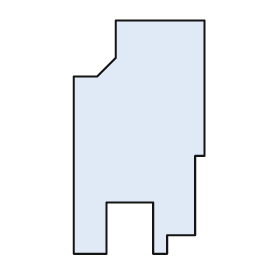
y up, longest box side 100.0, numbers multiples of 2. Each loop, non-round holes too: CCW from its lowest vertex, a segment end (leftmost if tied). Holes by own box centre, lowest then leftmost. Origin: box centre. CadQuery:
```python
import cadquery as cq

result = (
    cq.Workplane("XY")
    .moveTo(-28.0, -50.0)
    .lineTo(-14.0, -50.0)
    .lineTo(-14.0, -28.0)
    .lineTo(6.0, -28.0)
    .lineTo(6.0, -50.0)
    .lineTo(12.0, -50.0)
    .lineTo(12.0, -42.0)
    .lineTo(24.0, -42.0)
    .lineTo(24.0, -8.0)
    .lineTo(28.0, -8.0)
    .lineTo(28.0, 50.0)
    .lineTo(-10.0, 50.0)
    .lineTo(-10.0, 34.0)
    .lineTo(-18.0, 26.0)
    .lineTo(-28.0, 26.0)
    .close()
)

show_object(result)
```